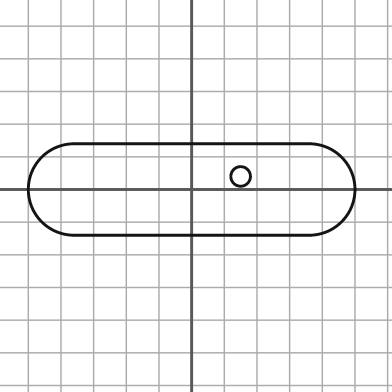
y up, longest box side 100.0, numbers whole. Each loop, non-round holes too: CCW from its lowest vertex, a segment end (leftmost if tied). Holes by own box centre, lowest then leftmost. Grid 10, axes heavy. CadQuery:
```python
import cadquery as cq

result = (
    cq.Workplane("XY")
    .moveTo(-36.0, -14.0)
    .lineTo(36.0, -14.0)
    .threePointArc((50.0, 0.0), (36.0, 14.0))
    .lineTo(-36.0, 14.0)
    .threePointArc((-50.0, 0.0), (-36.0, -14.0))
    .close()
    .moveTo(15.0, 4.0)
    .circle(3.0)
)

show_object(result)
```